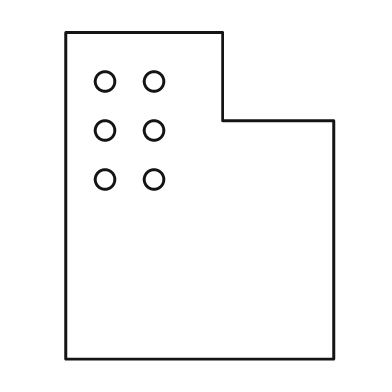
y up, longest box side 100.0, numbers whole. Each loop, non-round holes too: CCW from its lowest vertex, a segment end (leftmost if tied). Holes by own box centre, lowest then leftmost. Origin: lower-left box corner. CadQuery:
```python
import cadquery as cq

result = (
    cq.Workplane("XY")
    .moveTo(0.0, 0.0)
    .lineTo(82.0, 0.0)
    .lineTo(82.0, 73.0)
    .lineTo(48.0, 73.0)
    .lineTo(48.0, 100.0)
    .lineTo(0.0, 100.0)
    .close()
    .moveTo(12.0, 55.0)
    .circle(3.0)
    .moveTo(27.0, 55.0)
    .circle(3.0)
    .moveTo(12.0, 70.0)
    .circle(3.0)
    .moveTo(27.0, 70.0)
    .circle(3.0)
    .moveTo(12.0, 85.0)
    .circle(3.0)
    .moveTo(27.0, 85.0)
    .circle(3.0)
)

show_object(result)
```